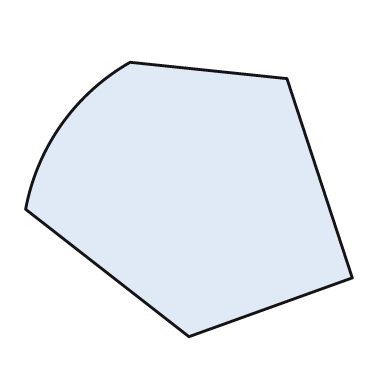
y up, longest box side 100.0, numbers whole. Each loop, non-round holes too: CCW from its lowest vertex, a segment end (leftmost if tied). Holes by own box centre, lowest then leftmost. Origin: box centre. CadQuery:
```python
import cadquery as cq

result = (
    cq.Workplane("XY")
    .moveTo(0.0, -42.0)
    .lineTo(50.0, -24.0)
    .lineTo(30.0, 37.0)
    .lineTo(-18.0, 42.0)
    .threePointArc((-39.0, 23.0), (-50.0, -3.0))
    .close()
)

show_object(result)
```